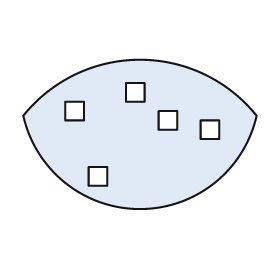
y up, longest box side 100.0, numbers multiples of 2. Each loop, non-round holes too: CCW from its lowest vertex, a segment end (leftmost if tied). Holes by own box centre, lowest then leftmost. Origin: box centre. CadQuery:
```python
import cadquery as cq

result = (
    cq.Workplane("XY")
    .moveTo(-50.0, 8.0)
    .threePointArc((0.0, -32.0), (50.0, 8.0))
    .threePointArc((0.0, 32.0), (-50.0, 8.0))
    .close()
    .moveTo(-22.0, -22.0)
    .lineTo(-14.0, -22.0)
    .lineTo(-14.0, -14.0)
    .lineTo(-22.0, -14.0)
    .close()
    .moveTo(26.0, -2.0)
    .lineTo(34.0, -2.0)
    .lineTo(34.0, 6.0)
    .lineTo(26.0, 6.0)
    .close()
    .moveTo(8.0, 2.0)
    .lineTo(16.0, 2.0)
    .lineTo(16.0, 10.0)
    .lineTo(8.0, 10.0)
    .close()
    .moveTo(-32.0, 6.0)
    .lineTo(-24.0, 6.0)
    .lineTo(-24.0, 14.0)
    .lineTo(-32.0, 14.0)
    .close()
    .moveTo(-6.0, 14.0)
    .lineTo(2.0, 14.0)
    .lineTo(2.0, 22.0)
    .lineTo(-6.0, 22.0)
    .close()
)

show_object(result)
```